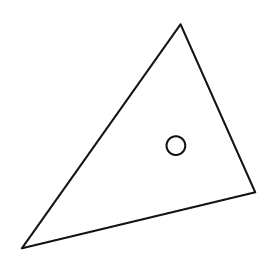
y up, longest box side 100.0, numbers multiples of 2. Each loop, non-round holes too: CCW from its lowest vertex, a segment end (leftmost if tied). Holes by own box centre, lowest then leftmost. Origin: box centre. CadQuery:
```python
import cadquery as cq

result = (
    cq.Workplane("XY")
    .moveTo(-50.0, -48.0)
    .lineTo(50.0, -24.0)
    .lineTo(18.0, 48.0)
    .close()
    .moveTo(16.0, -4.0)
    .circle(4.0)
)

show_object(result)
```